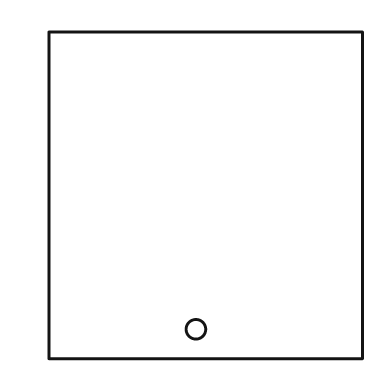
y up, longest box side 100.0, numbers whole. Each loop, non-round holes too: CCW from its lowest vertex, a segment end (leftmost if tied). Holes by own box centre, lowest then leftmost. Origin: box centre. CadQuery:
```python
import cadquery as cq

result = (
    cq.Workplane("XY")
    .moveTo(-48.0, -50.0)
    .lineTo(48.0, -50.0)
    .lineTo(48.0, 50.0)
    .lineTo(-48.0, 50.0)
    .close()
    .moveTo(-3.0, -41.0)
    .circle(3.0)
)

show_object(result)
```